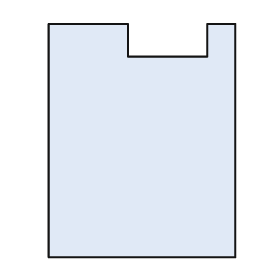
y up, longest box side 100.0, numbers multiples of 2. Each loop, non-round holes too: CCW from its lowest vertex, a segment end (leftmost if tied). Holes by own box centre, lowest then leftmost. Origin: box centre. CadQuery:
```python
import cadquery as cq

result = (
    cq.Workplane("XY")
    .moveTo(-40.0, -50.0)
    .lineTo(40.0, -50.0)
    .lineTo(40.0, 50.0)
    .lineTo(28.0, 50.0)
    .lineTo(28.0, 36.0)
    .lineTo(-6.0, 36.0)
    .lineTo(-6.0, 50.0)
    .lineTo(-40.0, 50.0)
    .close()
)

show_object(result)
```